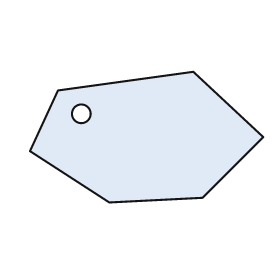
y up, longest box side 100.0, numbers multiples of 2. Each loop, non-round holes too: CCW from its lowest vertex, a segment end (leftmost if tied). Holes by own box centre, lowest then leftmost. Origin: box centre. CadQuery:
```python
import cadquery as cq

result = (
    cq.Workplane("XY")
    .moveTo(-16.0, -28.0)
    .lineTo(24.0, -26.0)
    .lineTo(50.0, 0.0)
    .lineTo(20.0, 28.0)
    .lineTo(-38.0, 20.0)
    .lineTo(-50.0, -6.0)
    .close()
    .moveTo(-28.0, 10.0)
    .circle(4.0)
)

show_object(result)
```